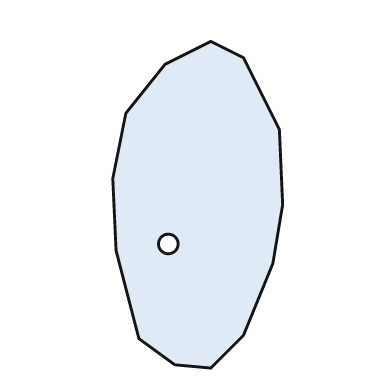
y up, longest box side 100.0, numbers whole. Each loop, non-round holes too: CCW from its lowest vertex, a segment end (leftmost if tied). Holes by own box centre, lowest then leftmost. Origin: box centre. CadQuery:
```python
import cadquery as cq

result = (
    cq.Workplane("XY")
    .moveTo(4.0, -50.0)
    .lineTo(14.0, -40.0)
    .lineTo(23.0, -18.0)
    .lineTo(26.0, 0.0)
    .lineTo(25.0, 23.0)
    .lineTo(14.0, 45.0)
    .lineTo(4.0, 50.0)
    .lineTo(-10.0, 43.0)
    .lineTo(-22.0, 28.0)
    .lineTo(-26.0, 8.0)
    .lineTo(-25.0, -14.0)
    .lineTo(-18.0, -41.0)
    .lineTo(-7.0, -49.0)
    .close()
    .moveTo(-9.0, -12.0)
    .circle(3.0)
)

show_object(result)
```